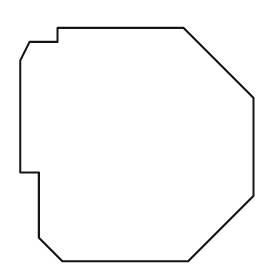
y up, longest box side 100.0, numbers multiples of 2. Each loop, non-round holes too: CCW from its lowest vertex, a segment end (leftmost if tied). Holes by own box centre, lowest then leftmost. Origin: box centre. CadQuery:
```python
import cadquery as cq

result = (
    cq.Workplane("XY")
    .moveTo(-32.0, -50.0)
    .lineTo(22.0, -50.0)
    .lineTo(50.0, -22.0)
    .lineTo(50.0, 20.0)
    .lineTo(20.0, 50.0)
    .lineTo(-34.0, 50.0)
    .lineTo(-34.0, 44.0)
    .lineTo(-46.0, 44.0)
    .lineTo(-50.0, 36.0)
    .lineTo(-50.0, -12.0)
    .lineTo(-42.0, -12.0)
    .lineTo(-42.0, -40.0)
    .close()
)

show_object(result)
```